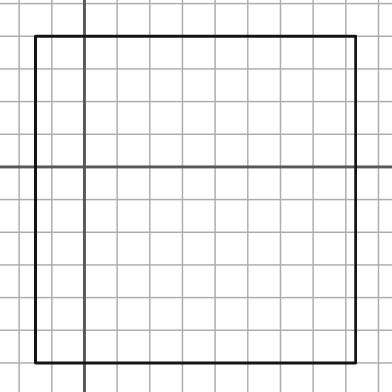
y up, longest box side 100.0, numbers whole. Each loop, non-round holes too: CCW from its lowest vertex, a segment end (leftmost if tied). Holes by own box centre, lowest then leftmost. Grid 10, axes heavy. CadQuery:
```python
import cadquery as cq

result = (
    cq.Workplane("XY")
    .moveTo(-15.0, -60.0)
    .lineTo(83.0, -60.0)
    .lineTo(83.0, 40.0)
    .lineTo(-15.0, 40.0)
    .close()
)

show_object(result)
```